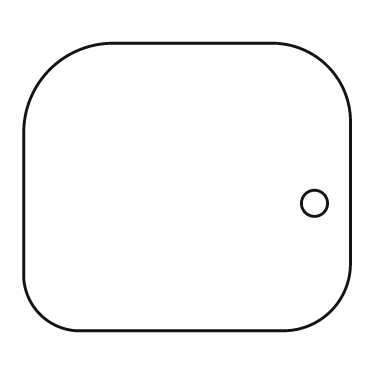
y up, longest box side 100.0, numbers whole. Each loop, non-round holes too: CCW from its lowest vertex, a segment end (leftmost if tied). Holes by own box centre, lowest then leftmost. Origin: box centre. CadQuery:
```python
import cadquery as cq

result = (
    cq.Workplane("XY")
    .moveTo(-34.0, -44.0)
    .lineTo(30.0, -44.0)
    .threePointArc((44.0, -38.0), (50.0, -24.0))
    .lineTo(50.0, 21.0)
    .threePointArc((43.0, 37.0), (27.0, 44.0))
    .lineTo(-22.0, 44.0)
    .threePointArc((-42.0, 36.0), (-50.0, 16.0))
    .lineTo(-50.0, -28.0)
    .threePointArc((-45.0, -39.0), (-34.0, -44.0))
    .close()
    .moveTo(39.0, -5.0)
    .circle(4.0)
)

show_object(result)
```